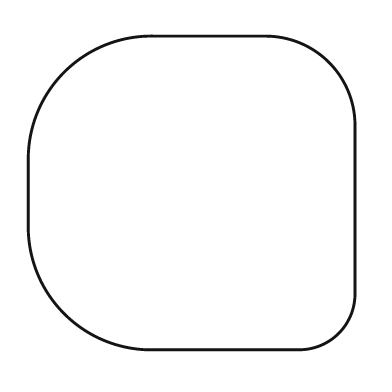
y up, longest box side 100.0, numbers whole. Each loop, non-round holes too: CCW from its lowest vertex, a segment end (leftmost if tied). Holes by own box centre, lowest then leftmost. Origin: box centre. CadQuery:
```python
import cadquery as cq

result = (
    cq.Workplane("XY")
    .moveTo(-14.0, -48.0)
    .lineTo(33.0, -48.0)
    .threePointArc((45.0, -43.0), (50.0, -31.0))
    .lineTo(50.0, 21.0)
    .threePointArc((42.0, 40.0), (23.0, 48.0))
    .lineTo(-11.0, 48.0)
    .threePointArc((-39.0, 37.0), (-50.0, 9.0))
    .lineTo(-50.0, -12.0)
    .threePointArc((-39.0, -37.0), (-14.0, -48.0))
    .close()
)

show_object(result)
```